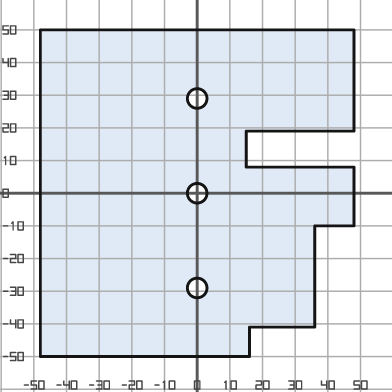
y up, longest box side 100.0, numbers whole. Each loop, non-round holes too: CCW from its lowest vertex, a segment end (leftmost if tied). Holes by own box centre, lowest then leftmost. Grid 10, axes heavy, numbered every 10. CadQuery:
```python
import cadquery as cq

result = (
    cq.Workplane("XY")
    .moveTo(-48.0, -50.0)
    .lineTo(16.0, -50.0)
    .lineTo(16.0, -41.0)
    .lineTo(36.0, -41.0)
    .lineTo(36.0, -10.0)
    .lineTo(48.0, -10.0)
    .lineTo(48.0, 8.0)
    .lineTo(15.0, 8.0)
    .lineTo(15.0, 19.0)
    .lineTo(48.0, 19.0)
    .lineTo(48.0, 50.0)
    .lineTo(-48.0, 50.0)
    .close()
    .moveTo(0.0, -29.0)
    .circle(3.0)
    .moveTo(0.0, 0.0)
    .circle(3.0)
    .moveTo(0.0, 29.0)
    .circle(3.0)
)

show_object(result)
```